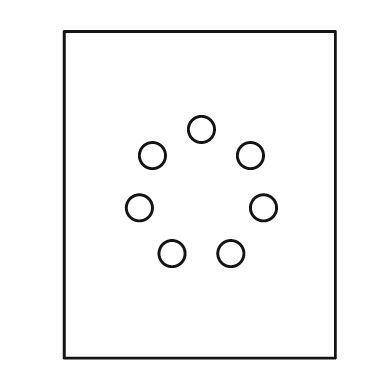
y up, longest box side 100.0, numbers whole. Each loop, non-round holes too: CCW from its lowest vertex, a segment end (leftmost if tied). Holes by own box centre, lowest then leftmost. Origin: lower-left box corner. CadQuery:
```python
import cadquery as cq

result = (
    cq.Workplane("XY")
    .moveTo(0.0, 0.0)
    .lineTo(83.0, 0.0)
    .lineTo(83.0, 100.0)
    .lineTo(0.0, 100.0)
    .close()
    .moveTo(33.0, 32.0)
    .circle(4.0)
    .moveTo(51.0, 32.0)
    .circle(4.0)
    .moveTo(23.0, 46.0)
    .circle(4.0)
    .moveTo(61.0, 46.0)
    .circle(4.0)
    .moveTo(27.0, 62.0)
    .circle(4.0)
    .moveTo(57.0, 62.0)
    .circle(4.0)
    .moveTo(42.0, 70.0)
    .circle(4.0)
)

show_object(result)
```